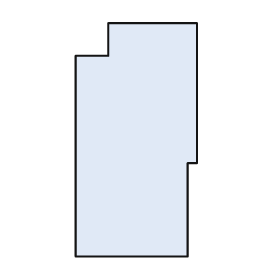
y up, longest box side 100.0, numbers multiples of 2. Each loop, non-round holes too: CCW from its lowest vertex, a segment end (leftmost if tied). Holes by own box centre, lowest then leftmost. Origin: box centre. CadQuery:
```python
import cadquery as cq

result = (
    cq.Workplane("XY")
    .moveTo(-26.0, -50.0)
    .lineTo(22.0, -50.0)
    .lineTo(22.0, -10.0)
    .lineTo(26.0, -10.0)
    .lineTo(26.0, 50.0)
    .lineTo(-12.0, 50.0)
    .lineTo(-12.0, 36.0)
    .lineTo(-26.0, 36.0)
    .close()
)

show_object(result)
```